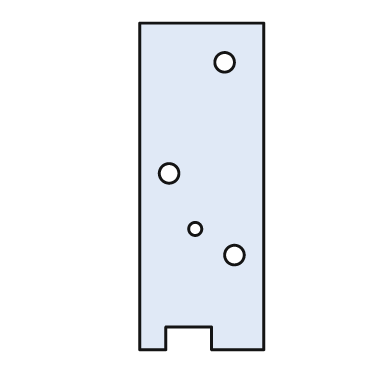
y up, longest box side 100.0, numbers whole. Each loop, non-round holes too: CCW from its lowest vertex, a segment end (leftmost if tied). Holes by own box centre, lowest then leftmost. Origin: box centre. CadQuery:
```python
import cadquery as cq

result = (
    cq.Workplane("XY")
    .moveTo(-19.0, -50.0)
    .lineTo(-11.0, -50.0)
    .lineTo(-11.0, -43.0)
    .lineTo(3.0, -43.0)
    .lineTo(3.0, -50.0)
    .lineTo(19.0, -50.0)
    .lineTo(19.0, 50.0)
    .lineTo(-19.0, 50.0)
    .close()
    .moveTo(10.0, -21.0)
    .circle(3.0)
    .moveTo(-2.0, -13.0)
    .circle(2.0)
    .moveTo(-10.0, 4.0)
    .circle(3.0)
    .moveTo(7.0, 38.0)
    .circle(3.0)
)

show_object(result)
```